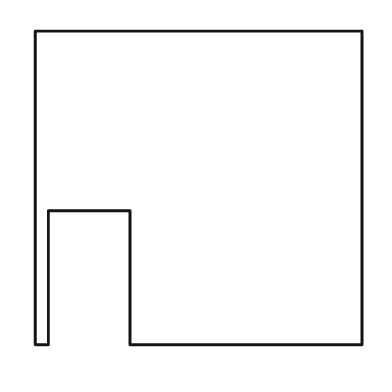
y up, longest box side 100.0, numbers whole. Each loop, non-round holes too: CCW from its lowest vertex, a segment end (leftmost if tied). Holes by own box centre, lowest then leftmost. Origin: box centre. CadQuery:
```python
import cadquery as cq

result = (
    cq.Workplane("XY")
    .moveTo(-50.0, -48.0)
    .lineTo(-46.0, -48.0)
    .lineTo(-46.0, -7.0)
    .lineTo(-21.0, -7.0)
    .lineTo(-21.0, -48.0)
    .lineTo(50.0, -48.0)
    .lineTo(50.0, 48.0)
    .lineTo(-50.0, 48.0)
    .close()
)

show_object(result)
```